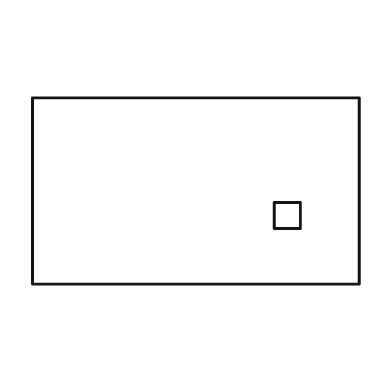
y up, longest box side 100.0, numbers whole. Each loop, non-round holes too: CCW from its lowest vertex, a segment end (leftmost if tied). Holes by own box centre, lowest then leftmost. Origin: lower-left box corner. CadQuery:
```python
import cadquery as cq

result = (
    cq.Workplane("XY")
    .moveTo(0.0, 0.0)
    .lineTo(100.0, 0.0)
    .lineTo(100.0, 57.0)
    .lineTo(0.0, 57.0)
    .close()
    .moveTo(74.0, 17.0)
    .lineTo(82.0, 17.0)
    .lineTo(82.0, 25.0)
    .lineTo(74.0, 25.0)
    .close()
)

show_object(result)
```